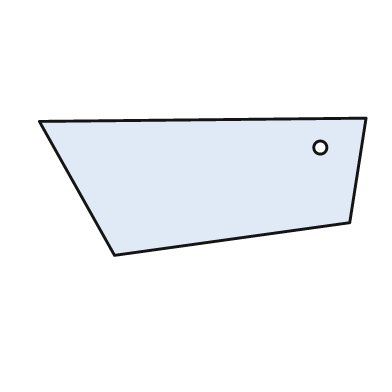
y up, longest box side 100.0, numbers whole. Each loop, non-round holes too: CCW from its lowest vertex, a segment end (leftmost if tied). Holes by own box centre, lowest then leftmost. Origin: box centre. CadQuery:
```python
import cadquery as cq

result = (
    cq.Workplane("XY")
    .moveTo(-27.0, -21.0)
    .lineTo(45.0, -11.0)
    .lineTo(50.0, 21.0)
    .lineTo(-50.0, 20.0)
    .close()
    .moveTo(36.0, 12.0)
    .circle(2.0)
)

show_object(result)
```